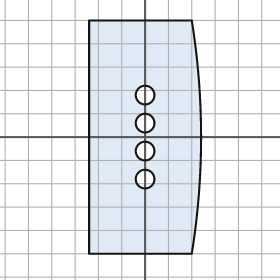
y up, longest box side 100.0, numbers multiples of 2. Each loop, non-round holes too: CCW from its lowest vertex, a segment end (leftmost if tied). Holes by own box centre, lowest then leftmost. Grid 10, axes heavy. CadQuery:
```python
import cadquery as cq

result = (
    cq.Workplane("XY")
    .moveTo(-24.0, -50.0)
    .lineTo(20.0, -50.0)
    .threePointArc((24.0, 0.0), (20.0, 50.0))
    .lineTo(-24.0, 50.0)
    .close()
    .moveTo(0.0, -18.0)
    .circle(4.0)
    .moveTo(0.0, -6.0)
    .circle(4.0)
    .moveTo(0.0, 6.0)
    .circle(4.0)
    .moveTo(0.0, 18.0)
    .circle(4.0)
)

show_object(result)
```